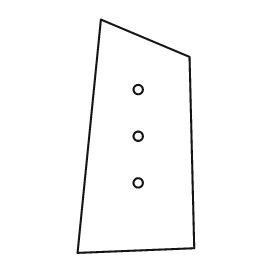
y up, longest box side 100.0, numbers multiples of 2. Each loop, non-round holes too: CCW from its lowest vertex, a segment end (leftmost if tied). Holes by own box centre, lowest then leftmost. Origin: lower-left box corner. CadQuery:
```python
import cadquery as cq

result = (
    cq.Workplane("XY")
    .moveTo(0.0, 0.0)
    .lineTo(50.0, 2.0)
    .lineTo(48.0, 84.0)
    .lineTo(10.0, 100.0)
    .close()
    .moveTo(26.0, 30.0)
    .circle(2.0)
    .moveTo(26.0, 50.0)
    .circle(2.0)
    .moveTo(26.0, 70.0)
    .circle(2.0)
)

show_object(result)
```